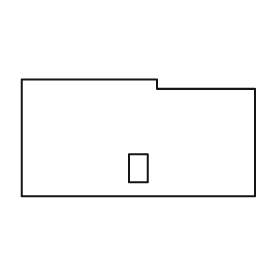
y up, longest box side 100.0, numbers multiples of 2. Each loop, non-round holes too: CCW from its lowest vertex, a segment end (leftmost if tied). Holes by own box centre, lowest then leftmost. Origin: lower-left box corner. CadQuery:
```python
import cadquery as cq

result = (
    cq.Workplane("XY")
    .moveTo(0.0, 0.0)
    .lineTo(100.0, 0.0)
    .lineTo(100.0, 46.0)
    .lineTo(58.0, 46.0)
    .lineTo(58.0, 50.0)
    .lineTo(0.0, 50.0)
    .close()
    .moveTo(46.0, 6.0)
    .lineTo(54.0, 6.0)
    .lineTo(54.0, 18.0)
    .lineTo(46.0, 18.0)
    .close()
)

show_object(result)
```